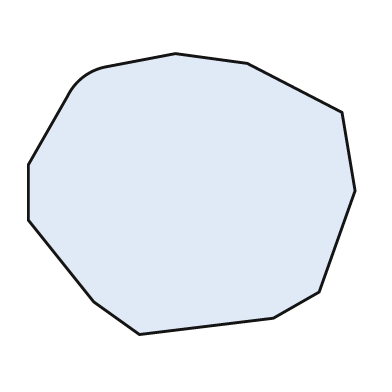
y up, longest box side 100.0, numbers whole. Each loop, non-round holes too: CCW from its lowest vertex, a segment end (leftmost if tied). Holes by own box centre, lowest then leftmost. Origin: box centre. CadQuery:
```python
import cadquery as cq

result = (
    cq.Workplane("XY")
    .moveTo(-16.0, -43.0)
    .lineTo(25.0, -38.0)
    .lineTo(39.0, -30.0)
    .lineTo(50.0, 1.0)
    .lineTo(46.0, 25.0)
    .lineTo(17.0, 40.0)
    .lineTo(-5.0, 43.0)
    .lineTo(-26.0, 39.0)
    .threePointArc((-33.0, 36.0), (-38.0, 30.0))
    .lineTo(-50.0, 9.0)
    .lineTo(-50.0, -8.0)
    .lineTo(-30.0, -33.0)
    .close()
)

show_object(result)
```